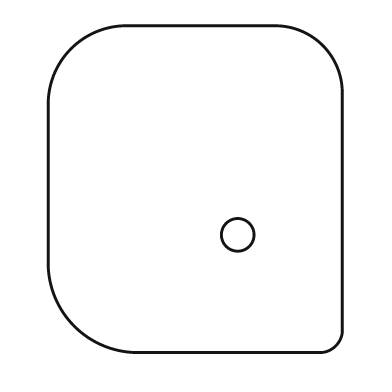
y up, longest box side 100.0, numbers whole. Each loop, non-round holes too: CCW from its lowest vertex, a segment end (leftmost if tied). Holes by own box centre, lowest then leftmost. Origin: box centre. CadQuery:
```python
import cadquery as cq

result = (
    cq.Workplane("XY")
    .moveTo(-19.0, -50.0)
    .lineTo(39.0, -50.0)
    .threePointArc((43.0, -48.0), (45.0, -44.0))
    .lineTo(45.0, 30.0)
    .threePointArc((39.0, 44.0), (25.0, 50.0))
    .lineTo(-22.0, 50.0)
    .threePointArc((-38.0, 43.0), (-45.0, 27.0))
    .lineTo(-45.0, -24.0)
    .threePointArc((-37.0, -42.0), (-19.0, -50.0))
    .close()
    .moveTo(13.0, -14.0)
    .circle(5.0)
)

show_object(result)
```